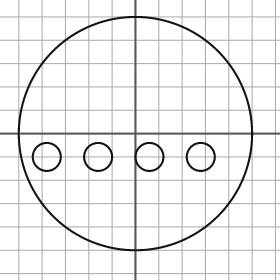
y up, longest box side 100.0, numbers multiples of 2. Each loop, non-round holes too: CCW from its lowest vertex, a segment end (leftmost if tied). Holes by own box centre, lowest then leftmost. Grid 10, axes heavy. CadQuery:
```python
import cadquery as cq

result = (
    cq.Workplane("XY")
    .moveTo(0.0, 0.0)
    .circle(50.0)
    .moveTo(-38.0, -10.0)
    .circle(6.0)
    .moveTo(-16.0, -10.0)
    .circle(6.0)
    .moveTo(6.0, -10.0)
    .circle(6.0)
    .moveTo(28.0, -10.0)
    .circle(6.0)
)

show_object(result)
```